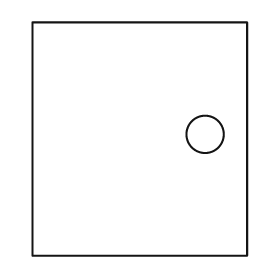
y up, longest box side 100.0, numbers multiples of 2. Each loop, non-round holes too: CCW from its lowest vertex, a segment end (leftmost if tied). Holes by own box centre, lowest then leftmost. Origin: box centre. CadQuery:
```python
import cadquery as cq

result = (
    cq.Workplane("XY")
    .moveTo(-46.0, -50.0)
    .lineTo(46.0, -50.0)
    .lineTo(46.0, 50.0)
    .lineTo(-46.0, 50.0)
    .close()
    .moveTo(28.0, 2.0)
    .circle(8.0)
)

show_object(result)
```